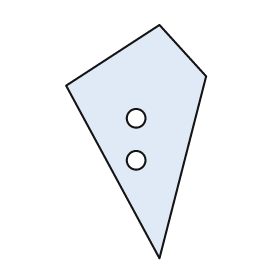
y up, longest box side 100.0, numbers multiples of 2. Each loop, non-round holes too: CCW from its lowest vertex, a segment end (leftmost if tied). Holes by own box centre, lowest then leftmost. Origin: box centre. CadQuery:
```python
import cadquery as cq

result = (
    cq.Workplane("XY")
    .moveTo(10.0, -50.0)
    .lineTo(30.0, 28.0)
    .lineTo(10.0, 50.0)
    .lineTo(-30.0, 24.0)
    .close()
    .moveTo(0.0, -8.0)
    .circle(4.0)
    .moveTo(0.0, 10.0)
    .circle(4.0)
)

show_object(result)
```